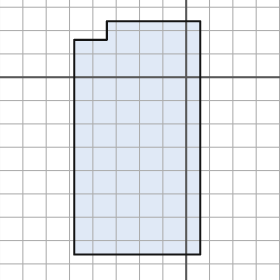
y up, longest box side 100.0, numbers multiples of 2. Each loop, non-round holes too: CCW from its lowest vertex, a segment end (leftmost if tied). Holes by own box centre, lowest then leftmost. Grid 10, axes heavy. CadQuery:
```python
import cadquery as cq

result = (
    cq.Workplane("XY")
    .moveTo(-48.0, -76.0)
    .lineTo(6.0, -76.0)
    .lineTo(6.0, 24.0)
    .lineTo(-34.0, 24.0)
    .lineTo(-34.0, 16.0)
    .lineTo(-48.0, 16.0)
    .close()
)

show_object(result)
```